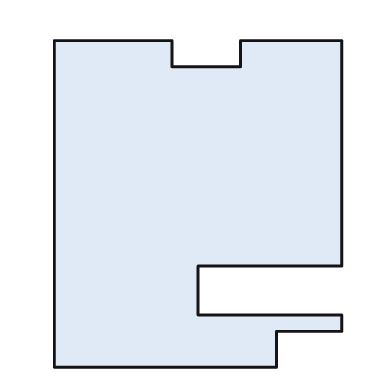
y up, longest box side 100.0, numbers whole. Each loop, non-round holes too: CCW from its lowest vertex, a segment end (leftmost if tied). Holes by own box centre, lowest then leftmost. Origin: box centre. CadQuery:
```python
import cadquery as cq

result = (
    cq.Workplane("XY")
    .moveTo(-44.0, -50.0)
    .lineTo(24.0, -50.0)
    .lineTo(24.0, -39.0)
    .lineTo(44.0, -39.0)
    .lineTo(44.0, -34.0)
    .lineTo(0.0, -34.0)
    .lineTo(0.0, -19.0)
    .lineTo(44.0, -19.0)
    .lineTo(44.0, 50.0)
    .lineTo(13.0, 50.0)
    .lineTo(13.0, 42.0)
    .lineTo(-8.0, 42.0)
    .lineTo(-8.0, 50.0)
    .lineTo(-44.0, 50.0)
    .close()
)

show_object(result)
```